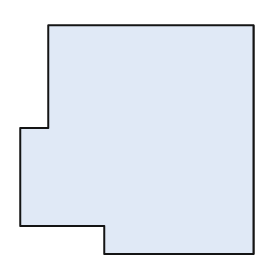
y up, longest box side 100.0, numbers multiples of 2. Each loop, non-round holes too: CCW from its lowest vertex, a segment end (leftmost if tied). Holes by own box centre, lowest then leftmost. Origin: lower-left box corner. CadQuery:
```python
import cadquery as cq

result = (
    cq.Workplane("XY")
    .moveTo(36.0, 0.0)
    .lineTo(100.0, 0.0)
    .lineTo(100.0, 98.0)
    .lineTo(12.0, 98.0)
    .lineTo(12.0, 54.0)
    .lineTo(0.0, 54.0)
    .lineTo(0.0, 12.0)
    .lineTo(36.0, 12.0)
    .close()
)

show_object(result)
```